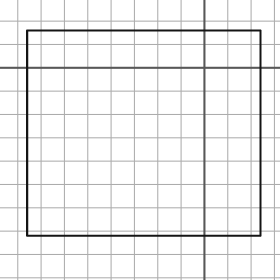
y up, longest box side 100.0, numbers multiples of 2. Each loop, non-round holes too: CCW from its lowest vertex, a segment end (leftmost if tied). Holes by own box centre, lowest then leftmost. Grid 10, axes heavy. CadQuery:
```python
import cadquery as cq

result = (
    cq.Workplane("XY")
    .moveTo(-76.0, -72.0)
    .lineTo(24.0, -72.0)
    .lineTo(24.0, 16.0)
    .lineTo(-76.0, 16.0)
    .close()
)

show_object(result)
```